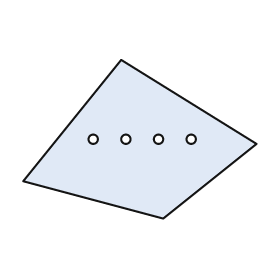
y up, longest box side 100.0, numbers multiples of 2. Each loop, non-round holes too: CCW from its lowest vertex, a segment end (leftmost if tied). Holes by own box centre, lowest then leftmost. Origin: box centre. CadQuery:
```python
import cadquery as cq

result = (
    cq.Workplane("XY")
    .moveTo(10.0, -34.0)
    .lineTo(50.0, -2.0)
    .lineTo(-8.0, 34.0)
    .lineTo(-50.0, -18.0)
    .close()
    .moveTo(-20.0, 0.0)
    .circle(2.0)
    .moveTo(-6.0, 0.0)
    .circle(2.0)
    .moveTo(8.0, 0.0)
    .circle(2.0)
    .moveTo(22.0, 0.0)
    .circle(2.0)
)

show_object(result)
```